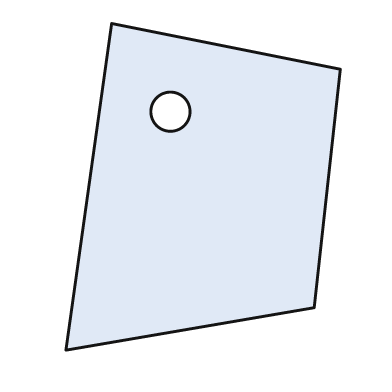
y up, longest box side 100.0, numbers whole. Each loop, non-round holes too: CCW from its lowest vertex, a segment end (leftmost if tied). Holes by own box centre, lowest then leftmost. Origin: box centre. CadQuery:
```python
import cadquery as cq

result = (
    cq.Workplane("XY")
    .moveTo(-42.0, -50.0)
    .lineTo(34.0, -37.0)
    .lineTo(42.0, 36.0)
    .lineTo(-28.0, 50.0)
    .close()
    .moveTo(-10.0, 23.0)
    .circle(6.0)
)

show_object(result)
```